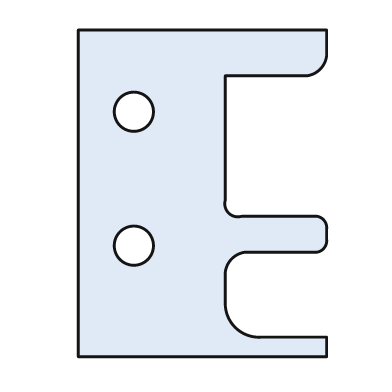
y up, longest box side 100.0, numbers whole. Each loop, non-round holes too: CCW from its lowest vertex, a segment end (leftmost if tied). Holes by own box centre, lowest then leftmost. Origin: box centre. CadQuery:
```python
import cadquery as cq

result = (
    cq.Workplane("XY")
    .moveTo(-38.0, -50.0)
    .lineTo(38.0, -50.0)
    .lineTo(38.0, -44.0)
    .lineTo(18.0, -44.0)
    .threePointArc((10.0, -41.0), (7.0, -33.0))
    .lineTo(7.0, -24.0)
    .threePointArc((9.0, -20.0), (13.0, -18.0))
    .lineTo(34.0, -18.0)
    .threePointArc((37.0, -17.0), (38.0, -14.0))
    .lineTo(38.0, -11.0)
    .threePointArc((37.0, -8.0), (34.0, -7.0))
    .lineTo(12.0, -7.0)
    .threePointArc((8.0, -6.0), (7.0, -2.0))
    .lineTo(7.0, 36.0)
    .lineTo(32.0, 36.0)
    .threePointArc((36.0, 38.0), (38.0, 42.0))
    .lineTo(38.0, 50.0)
    .lineTo(-38.0, 50.0)
    .close()
    .moveTo(-21.0, -16.0)
    .circle(6.0)
    .moveTo(-21.0, 25.0)
    .circle(6.0)
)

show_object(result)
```